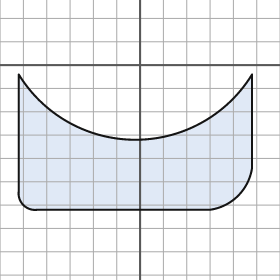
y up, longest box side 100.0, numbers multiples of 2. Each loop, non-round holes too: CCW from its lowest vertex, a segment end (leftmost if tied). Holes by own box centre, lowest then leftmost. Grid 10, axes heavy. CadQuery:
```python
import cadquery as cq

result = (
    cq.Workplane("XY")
    .moveTo(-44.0, -62.0)
    .lineTo(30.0, -62.0)
    .threePointArc((42.0, -56.0), (48.0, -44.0))
    .lineTo(48.0, -4.0)
    .threePointArc((-2.0, -32.0), (-52.0, -4.0))
    .lineTo(-52.0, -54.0)
    .threePointArc((-50.0, -60.0), (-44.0, -62.0))
    .close()
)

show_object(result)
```